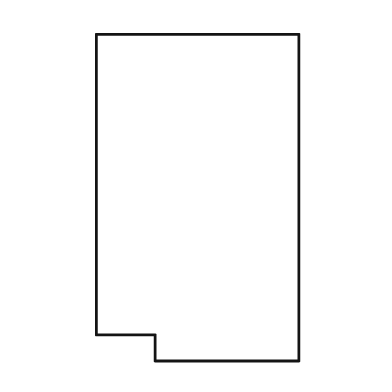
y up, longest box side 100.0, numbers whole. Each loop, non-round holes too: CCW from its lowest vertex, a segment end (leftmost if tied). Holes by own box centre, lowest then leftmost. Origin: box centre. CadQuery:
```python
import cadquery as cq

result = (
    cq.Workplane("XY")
    .moveTo(-13.0, -50.0)
    .lineTo(31.0, -50.0)
    .lineTo(31.0, 50.0)
    .lineTo(-31.0, 50.0)
    .lineTo(-31.0, -42.0)
    .lineTo(-13.0, -42.0)
    .close()
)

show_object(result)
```